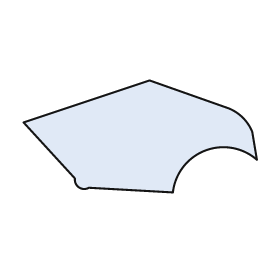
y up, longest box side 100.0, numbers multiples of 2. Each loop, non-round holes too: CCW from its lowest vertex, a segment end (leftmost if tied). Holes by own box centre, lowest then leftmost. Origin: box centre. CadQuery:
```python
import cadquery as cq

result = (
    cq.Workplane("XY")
    .moveTo(14.0, -24.0)
    .threePointArc((28.0, -6.0), (50.0, -10.0))
    .lineTo(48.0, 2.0)
    .threePointArc((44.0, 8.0), (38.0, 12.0))
    .lineTo(4.0, 24.0)
    .lineTo(-50.0, 6.0)
    .lineTo(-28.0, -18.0)
    .threePointArc((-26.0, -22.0), (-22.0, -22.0))
    .close()
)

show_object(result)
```